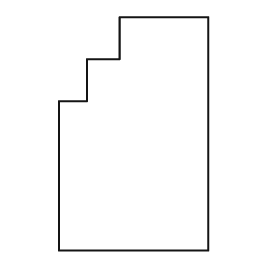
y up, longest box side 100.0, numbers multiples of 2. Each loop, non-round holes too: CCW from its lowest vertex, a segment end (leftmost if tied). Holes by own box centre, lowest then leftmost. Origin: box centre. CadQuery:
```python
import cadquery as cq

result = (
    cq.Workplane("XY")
    .moveTo(-32.0, -50.0)
    .lineTo(32.0, -50.0)
    .lineTo(32.0, 50.0)
    .lineTo(-6.0, 50.0)
    .lineTo(-6.0, 32.0)
    .lineTo(-20.0, 32.0)
    .lineTo(-20.0, 14.0)
    .lineTo(-32.0, 14.0)
    .close()
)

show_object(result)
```